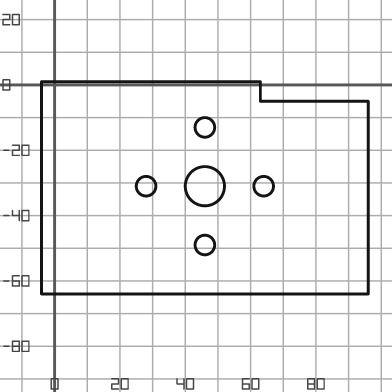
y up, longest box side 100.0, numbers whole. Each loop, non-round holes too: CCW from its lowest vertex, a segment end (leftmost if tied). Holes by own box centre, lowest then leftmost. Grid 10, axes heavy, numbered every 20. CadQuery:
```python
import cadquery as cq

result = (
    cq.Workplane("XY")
    .moveTo(-4.0, -64.0)
    .lineTo(96.0, -64.0)
    .lineTo(96.0, -5.0)
    .lineTo(63.0, -5.0)
    .lineTo(63.0, 1.0)
    .lineTo(-4.0, 1.0)
    .close()
    .moveTo(46.0, -49.0)
    .circle(3.0)
    .moveTo(28.0, -31.0)
    .circle(3.0)
    .moveTo(46.0, -31.0)
    .circle(6.0)
    .moveTo(64.0, -31.0)
    .circle(3.0)
    .moveTo(46.0, -13.0)
    .circle(3.0)
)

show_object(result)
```